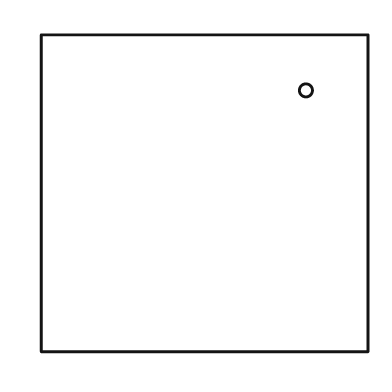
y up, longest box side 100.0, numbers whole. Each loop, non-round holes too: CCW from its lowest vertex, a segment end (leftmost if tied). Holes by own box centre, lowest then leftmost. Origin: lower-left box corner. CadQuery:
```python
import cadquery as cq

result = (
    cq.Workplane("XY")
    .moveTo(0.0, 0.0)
    .lineTo(100.0, 0.0)
    .lineTo(100.0, 97.0)
    .lineTo(0.0, 97.0)
    .close()
    .moveTo(81.0, 80.0)
    .circle(2.0)
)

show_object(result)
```